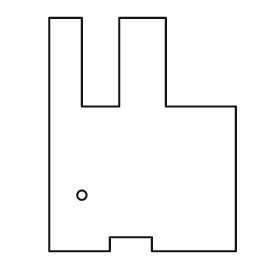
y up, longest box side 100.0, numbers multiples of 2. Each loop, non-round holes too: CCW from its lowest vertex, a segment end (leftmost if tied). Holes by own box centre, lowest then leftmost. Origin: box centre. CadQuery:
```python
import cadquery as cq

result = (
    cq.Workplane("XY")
    .moveTo(-40.0, -50.0)
    .lineTo(-14.0, -50.0)
    .lineTo(-14.0, -44.0)
    .lineTo(4.0, -44.0)
    .lineTo(4.0, -50.0)
    .lineTo(40.0, -50.0)
    .lineTo(40.0, 12.0)
    .lineTo(10.0, 12.0)
    .lineTo(10.0, 50.0)
    .lineTo(-10.0, 50.0)
    .lineTo(-10.0, 12.0)
    .lineTo(-26.0, 12.0)
    .lineTo(-26.0, 50.0)
    .lineTo(-40.0, 50.0)
    .close()
    .moveTo(-26.0, -26.0)
    .circle(2.0)
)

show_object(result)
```